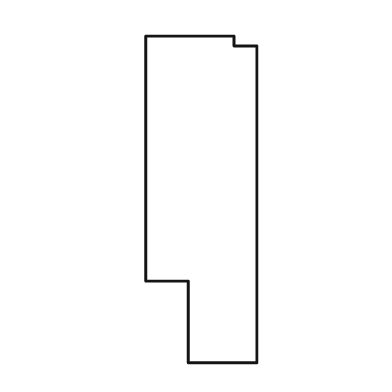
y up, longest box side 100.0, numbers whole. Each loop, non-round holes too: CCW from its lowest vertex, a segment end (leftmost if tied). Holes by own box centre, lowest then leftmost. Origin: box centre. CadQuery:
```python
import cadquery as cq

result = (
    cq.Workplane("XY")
    .moveTo(-4.0, -50.0)
    .lineTo(17.0, -50.0)
    .lineTo(17.0, 47.0)
    .lineTo(10.0, 47.0)
    .lineTo(10.0, 50.0)
    .lineTo(-17.0, 50.0)
    .lineTo(-17.0, -25.0)
    .lineTo(-4.0, -25.0)
    .close()
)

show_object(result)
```